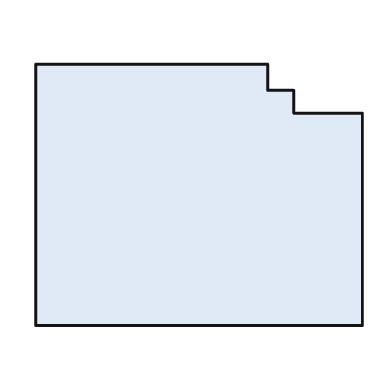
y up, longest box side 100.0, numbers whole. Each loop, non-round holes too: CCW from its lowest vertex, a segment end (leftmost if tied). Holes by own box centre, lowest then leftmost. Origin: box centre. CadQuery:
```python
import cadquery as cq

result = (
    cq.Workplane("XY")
    .moveTo(-50.0, -40.0)
    .lineTo(50.0, -40.0)
    .lineTo(50.0, 25.0)
    .lineTo(29.0, 25.0)
    .lineTo(29.0, 32.0)
    .lineTo(21.0, 32.0)
    .lineTo(21.0, 40.0)
    .lineTo(-50.0, 40.0)
    .close()
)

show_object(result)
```